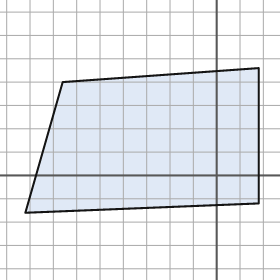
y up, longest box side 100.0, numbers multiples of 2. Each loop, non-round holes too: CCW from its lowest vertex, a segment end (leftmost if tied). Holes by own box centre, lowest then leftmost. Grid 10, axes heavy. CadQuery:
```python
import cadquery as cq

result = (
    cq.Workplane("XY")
    .moveTo(-82.0, -16.0)
    .lineTo(18.0, -12.0)
    .lineTo(18.0, 46.0)
    .lineTo(-66.0, 40.0)
    .close()
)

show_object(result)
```